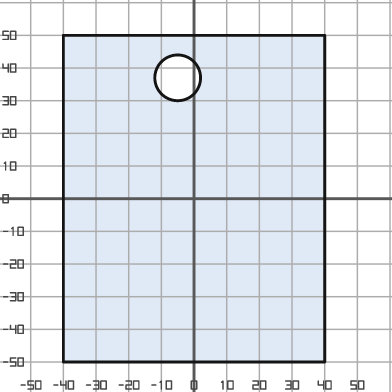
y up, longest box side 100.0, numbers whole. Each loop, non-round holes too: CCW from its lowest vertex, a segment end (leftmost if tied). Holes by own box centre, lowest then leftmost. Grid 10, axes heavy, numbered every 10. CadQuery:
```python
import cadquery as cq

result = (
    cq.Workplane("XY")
    .moveTo(-40.0, -50.0)
    .lineTo(40.0, -50.0)
    .lineTo(40.0, 50.0)
    .lineTo(-40.0, 50.0)
    .close()
    .moveTo(-5.0, 37.0)
    .circle(7.0)
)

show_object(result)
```